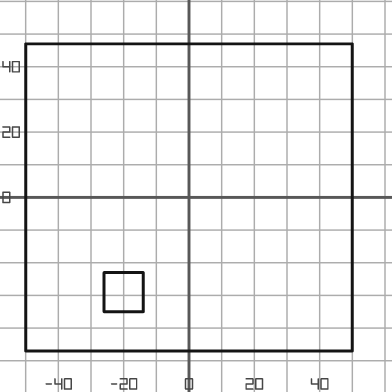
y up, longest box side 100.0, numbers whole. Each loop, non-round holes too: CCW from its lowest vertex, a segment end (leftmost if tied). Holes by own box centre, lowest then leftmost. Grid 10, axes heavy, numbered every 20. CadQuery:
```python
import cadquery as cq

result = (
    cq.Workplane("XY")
    .moveTo(-50.0, -47.0)
    .lineTo(50.0, -47.0)
    .lineTo(50.0, 47.0)
    .lineTo(-50.0, 47.0)
    .close()
    .moveTo(-26.0, -35.0)
    .lineTo(-14.0, -35.0)
    .lineTo(-14.0, -23.0)
    .lineTo(-26.0, -23.0)
    .close()
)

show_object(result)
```